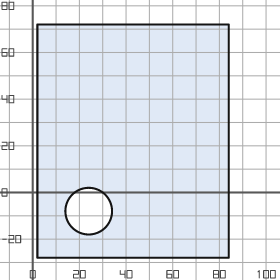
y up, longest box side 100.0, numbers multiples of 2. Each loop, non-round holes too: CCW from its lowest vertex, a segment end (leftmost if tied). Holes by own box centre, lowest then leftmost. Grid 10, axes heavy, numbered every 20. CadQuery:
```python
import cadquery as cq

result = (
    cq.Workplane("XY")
    .moveTo(2.0, -28.0)
    .lineTo(84.0, -28.0)
    .lineTo(84.0, 72.0)
    .lineTo(2.0, 72.0)
    .close()
    .moveTo(24.0, -8.0)
    .circle(10.0)
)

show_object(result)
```